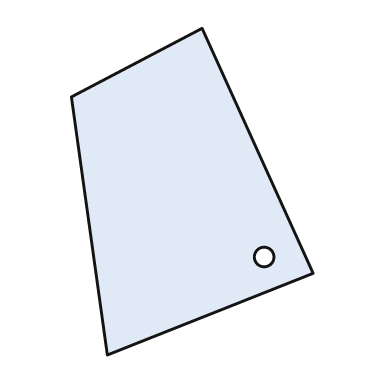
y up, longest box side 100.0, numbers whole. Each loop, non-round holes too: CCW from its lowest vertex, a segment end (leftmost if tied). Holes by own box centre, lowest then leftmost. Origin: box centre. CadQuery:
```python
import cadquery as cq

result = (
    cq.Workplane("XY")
    .moveTo(-26.0, -50.0)
    .lineTo(37.0, -25.0)
    .lineTo(3.0, 50.0)
    .lineTo(-37.0, 29.0)
    .close()
    .moveTo(22.0, -20.0)
    .circle(3.0)
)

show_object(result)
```